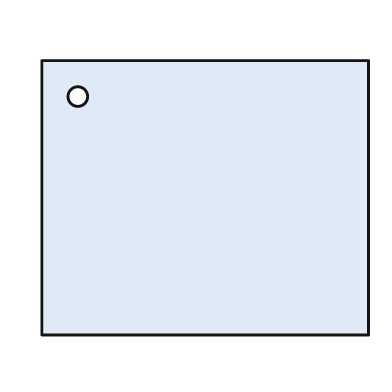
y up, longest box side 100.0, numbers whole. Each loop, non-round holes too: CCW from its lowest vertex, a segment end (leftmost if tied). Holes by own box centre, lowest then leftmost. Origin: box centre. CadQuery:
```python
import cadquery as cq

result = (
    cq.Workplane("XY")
    .moveTo(-50.0, -42.0)
    .lineTo(50.0, -42.0)
    .lineTo(50.0, 42.0)
    .lineTo(-50.0, 42.0)
    .close()
    .moveTo(-39.0, 31.0)
    .circle(3.0)
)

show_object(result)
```